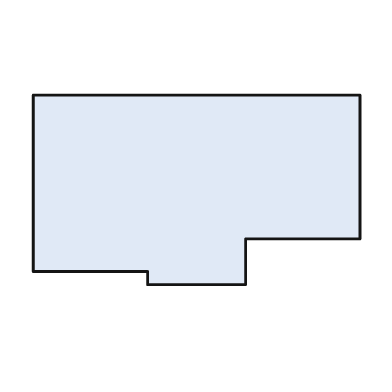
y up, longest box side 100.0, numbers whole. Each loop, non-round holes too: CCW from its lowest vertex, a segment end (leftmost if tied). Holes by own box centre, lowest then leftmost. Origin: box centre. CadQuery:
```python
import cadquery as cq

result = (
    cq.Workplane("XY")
    .moveTo(-15.0, -29.0)
    .lineTo(15.0, -29.0)
    .lineTo(15.0, -15.0)
    .lineTo(50.0, -15.0)
    .lineTo(50.0, 29.0)
    .lineTo(-50.0, 29.0)
    .lineTo(-50.0, -25.0)
    .lineTo(-15.0, -25.0)
    .close()
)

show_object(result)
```